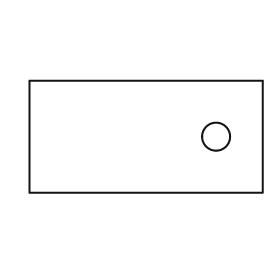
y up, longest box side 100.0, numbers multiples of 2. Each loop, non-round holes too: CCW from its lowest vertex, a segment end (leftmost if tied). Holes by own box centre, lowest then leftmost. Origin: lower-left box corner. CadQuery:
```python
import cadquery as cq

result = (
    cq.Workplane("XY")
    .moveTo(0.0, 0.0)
    .lineTo(100.0, 0.0)
    .lineTo(100.0, 48.0)
    .lineTo(0.0, 48.0)
    .close()
    .moveTo(80.0, 24.0)
    .circle(6.0)
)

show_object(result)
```